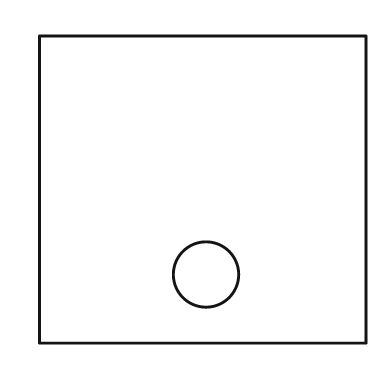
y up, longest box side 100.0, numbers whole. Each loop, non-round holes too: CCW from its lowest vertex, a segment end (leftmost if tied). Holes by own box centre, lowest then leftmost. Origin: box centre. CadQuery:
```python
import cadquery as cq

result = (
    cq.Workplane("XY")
    .moveTo(-50.0, -47.0)
    .lineTo(50.0, -47.0)
    .lineTo(50.0, 47.0)
    .lineTo(-50.0, 47.0)
    .close()
    .moveTo(1.0, -26.0)
    .circle(10.0)
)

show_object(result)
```